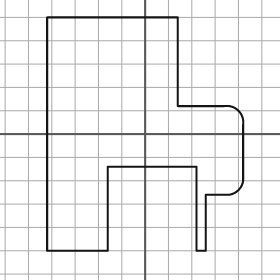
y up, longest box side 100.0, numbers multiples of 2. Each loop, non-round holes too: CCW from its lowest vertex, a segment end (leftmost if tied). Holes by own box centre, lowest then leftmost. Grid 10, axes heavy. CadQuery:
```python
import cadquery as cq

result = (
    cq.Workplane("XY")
    .moveTo(-42.0, -50.0)
    .lineTo(-16.0, -50.0)
    .lineTo(-16.0, -14.0)
    .lineTo(22.0, -14.0)
    .lineTo(22.0, -50.0)
    .lineTo(26.0, -50.0)
    .lineTo(26.0, -26.0)
    .lineTo(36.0, -26.0)
    .threePointArc((40.0, -24.0), (42.0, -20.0))
    .lineTo(42.0, 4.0)
    .threePointArc((40.0, 10.0), (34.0, 12.0))
    .lineTo(14.0, 12.0)
    .lineTo(14.0, 50.0)
    .lineTo(-42.0, 50.0)
    .close()
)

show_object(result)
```